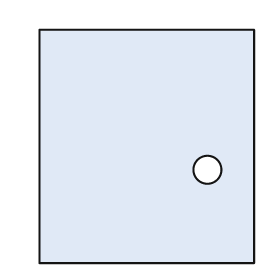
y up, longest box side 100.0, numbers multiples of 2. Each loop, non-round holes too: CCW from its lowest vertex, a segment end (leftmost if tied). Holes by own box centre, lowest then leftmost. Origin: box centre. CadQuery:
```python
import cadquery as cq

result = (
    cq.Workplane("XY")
    .moveTo(-46.0, -50.0)
    .lineTo(46.0, -50.0)
    .lineTo(46.0, 50.0)
    .lineTo(-46.0, 50.0)
    .close()
    .moveTo(26.0, -10.0)
    .circle(6.0)
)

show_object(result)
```